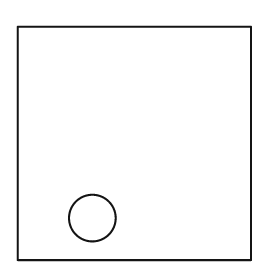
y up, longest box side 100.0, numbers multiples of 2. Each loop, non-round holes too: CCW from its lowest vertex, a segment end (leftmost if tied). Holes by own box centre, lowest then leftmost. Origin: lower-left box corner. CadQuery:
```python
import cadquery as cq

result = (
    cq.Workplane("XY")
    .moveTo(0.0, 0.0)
    .lineTo(100.0, 0.0)
    .lineTo(100.0, 100.0)
    .lineTo(0.0, 100.0)
    .close()
    .moveTo(32.0, 18.0)
    .circle(10.0)
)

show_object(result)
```